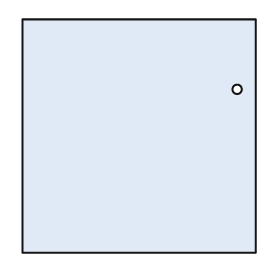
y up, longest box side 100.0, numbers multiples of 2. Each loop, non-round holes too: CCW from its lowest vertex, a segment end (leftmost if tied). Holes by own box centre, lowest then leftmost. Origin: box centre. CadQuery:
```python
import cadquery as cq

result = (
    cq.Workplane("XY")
    .moveTo(-50.0, -50.0)
    .lineTo(50.0, -50.0)
    .lineTo(50.0, 50.0)
    .lineTo(-50.0, 50.0)
    .close()
    .moveTo(42.0, 20.0)
    .circle(2.0)
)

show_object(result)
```